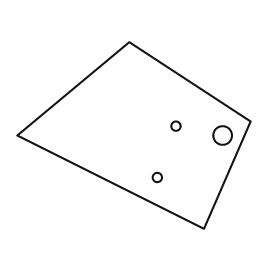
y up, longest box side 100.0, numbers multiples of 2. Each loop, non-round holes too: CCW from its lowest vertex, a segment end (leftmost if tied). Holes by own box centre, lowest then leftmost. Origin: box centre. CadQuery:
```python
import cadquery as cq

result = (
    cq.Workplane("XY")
    .moveTo(30.0, -40.0)
    .lineTo(50.0, 6.0)
    .lineTo(-2.0, 40.0)
    .lineTo(-50.0, 0.0)
    .close()
    .moveTo(10.0, -18.0)
    .circle(2.0)
    .moveTo(38.0, 0.0)
    .circle(4.0)
    .moveTo(18.0, 4.0)
    .circle(2.0)
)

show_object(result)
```